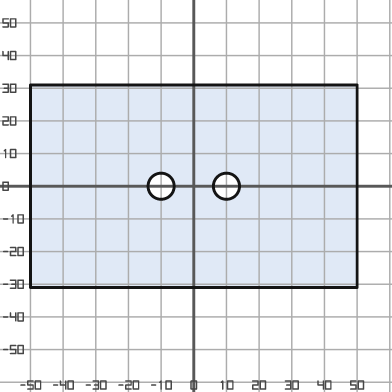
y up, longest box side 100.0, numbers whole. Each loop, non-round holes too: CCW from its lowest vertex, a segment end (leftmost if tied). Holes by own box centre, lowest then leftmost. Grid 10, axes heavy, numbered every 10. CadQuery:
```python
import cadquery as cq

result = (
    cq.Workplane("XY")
    .moveTo(-50.0, -31.0)
    .lineTo(50.0, -31.0)
    .lineTo(50.0, 31.0)
    .lineTo(-50.0, 31.0)
    .close()
    .moveTo(-10.0, 0.0)
    .circle(4.0)
    .moveTo(10.0, 0.0)
    .circle(4.0)
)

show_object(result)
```